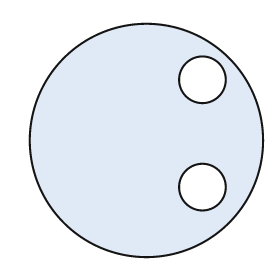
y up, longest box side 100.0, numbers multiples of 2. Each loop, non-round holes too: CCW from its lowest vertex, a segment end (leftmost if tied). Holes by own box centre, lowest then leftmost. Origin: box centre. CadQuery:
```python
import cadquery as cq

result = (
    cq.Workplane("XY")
    .moveTo(0.0, 0.0)
    .circle(50.0)
    .moveTo(24.0, -20.0)
    .circle(10.0)
    .moveTo(24.0, 26.0)
    .circle(10.0)
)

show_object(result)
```